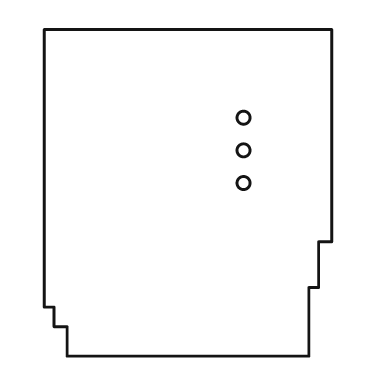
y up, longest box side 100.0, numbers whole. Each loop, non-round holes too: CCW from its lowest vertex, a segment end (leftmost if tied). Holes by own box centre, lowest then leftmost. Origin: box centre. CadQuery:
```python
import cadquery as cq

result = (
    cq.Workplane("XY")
    .moveTo(-37.0, -50.0)
    .lineTo(37.0, -50.0)
    .lineTo(37.0, -29.0)
    .lineTo(40.0, -29.0)
    .lineTo(40.0, -15.0)
    .lineTo(44.0, -15.0)
    .lineTo(44.0, 50.0)
    .lineTo(-44.0, 50.0)
    .lineTo(-44.0, -35.0)
    .lineTo(-41.0, -35.0)
    .lineTo(-41.0, -41.0)
    .lineTo(-37.0, -41.0)
    .close()
    .moveTo(17.0, 3.0)
    .circle(2.0)
    .moveTo(17.0, 13.0)
    .circle(2.0)
    .moveTo(17.0, 23.0)
    .circle(2.0)
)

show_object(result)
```